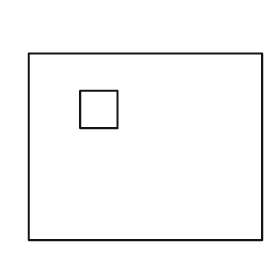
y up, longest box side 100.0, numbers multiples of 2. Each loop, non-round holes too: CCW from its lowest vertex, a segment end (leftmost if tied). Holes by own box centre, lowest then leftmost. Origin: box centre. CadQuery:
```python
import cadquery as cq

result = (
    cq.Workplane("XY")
    .moveTo(-50.0, -40.0)
    .lineTo(50.0, -40.0)
    .lineTo(50.0, 40.0)
    .lineTo(-50.0, 40.0)
    .close()
    .moveTo(-28.0, 8.0)
    .lineTo(-12.0, 8.0)
    .lineTo(-12.0, 24.0)
    .lineTo(-28.0, 24.0)
    .close()
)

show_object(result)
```